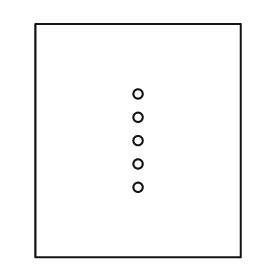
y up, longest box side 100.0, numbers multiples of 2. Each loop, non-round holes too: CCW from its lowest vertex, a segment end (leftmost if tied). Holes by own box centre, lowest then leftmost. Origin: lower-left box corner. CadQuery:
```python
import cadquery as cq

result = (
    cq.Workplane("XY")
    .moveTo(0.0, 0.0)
    .lineTo(88.0, 0.0)
    .lineTo(88.0, 100.0)
    .lineTo(0.0, 100.0)
    .close()
    .moveTo(44.0, 30.0)
    .circle(2.0)
    .moveTo(44.0, 40.0)
    .circle(2.0)
    .moveTo(44.0, 50.0)
    .circle(2.0)
    .moveTo(44.0, 60.0)
    .circle(2.0)
    .moveTo(44.0, 70.0)
    .circle(2.0)
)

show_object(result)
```